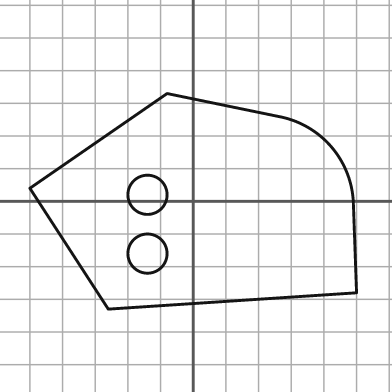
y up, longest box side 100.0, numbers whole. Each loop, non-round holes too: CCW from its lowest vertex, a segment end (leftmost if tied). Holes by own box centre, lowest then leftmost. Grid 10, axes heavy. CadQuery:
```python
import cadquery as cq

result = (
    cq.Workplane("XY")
    .moveTo(-26.0, -33.0)
    .lineTo(50.0, -28.0)
    .lineTo(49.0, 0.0)
    .threePointArc((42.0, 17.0), (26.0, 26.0))
    .lineTo(-8.0, 33.0)
    .lineTo(-50.0, 4.0)
    .close()
    .moveTo(-14.0, -16.0)
    .circle(6.0)
    .moveTo(-14.0, 2.0)
    .circle(6.0)
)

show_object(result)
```